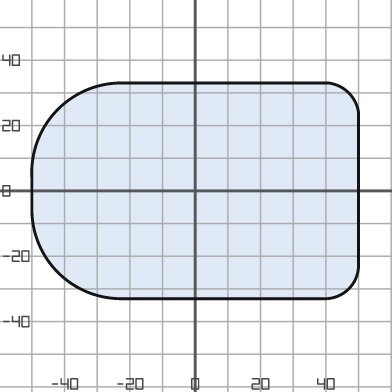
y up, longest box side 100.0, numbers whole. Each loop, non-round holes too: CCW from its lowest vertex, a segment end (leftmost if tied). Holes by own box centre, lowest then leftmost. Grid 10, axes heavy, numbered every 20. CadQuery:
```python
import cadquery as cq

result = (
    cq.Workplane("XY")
    .moveTo(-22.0, -33.0)
    .lineTo(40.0, -33.0)
    .threePointArc((47.0, -30.0), (50.0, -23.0))
    .lineTo(50.0, 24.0)
    .threePointArc((47.0, 30.0), (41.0, 33.0))
    .lineTo(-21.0, 33.0)
    .threePointArc((-42.0, 25.0), (-50.0, 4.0))
    .lineTo(-50.0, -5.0)
    .threePointArc((-42.0, -25.0), (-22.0, -33.0))
    .close()
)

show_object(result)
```